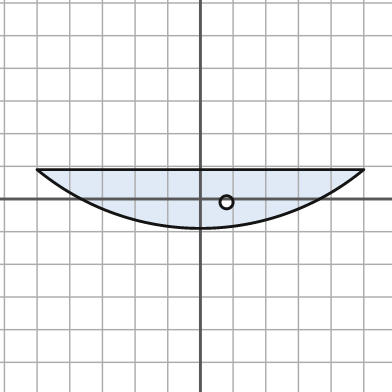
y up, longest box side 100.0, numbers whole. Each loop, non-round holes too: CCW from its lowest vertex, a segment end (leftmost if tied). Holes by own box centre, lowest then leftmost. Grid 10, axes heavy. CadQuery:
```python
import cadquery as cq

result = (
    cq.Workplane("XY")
    .moveTo(-50.0, 9.0)
    .threePointArc((0.0, -9.0), (50.0, 9.0))
    .close()
    .moveTo(8.0, -1.0)
    .circle(2.0)
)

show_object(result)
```